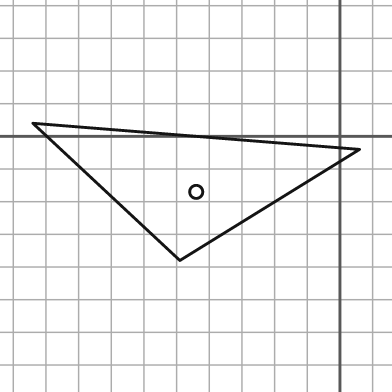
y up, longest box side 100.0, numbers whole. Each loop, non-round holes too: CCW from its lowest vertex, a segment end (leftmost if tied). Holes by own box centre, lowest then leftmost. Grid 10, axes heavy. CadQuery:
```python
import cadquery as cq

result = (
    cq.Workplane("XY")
    .moveTo(-49.0, -38.0)
    .lineTo(6.0, -4.0)
    .lineTo(-94.0, 4.0)
    .close()
    .moveTo(-44.0, -17.0)
    .circle(2.0)
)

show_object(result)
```